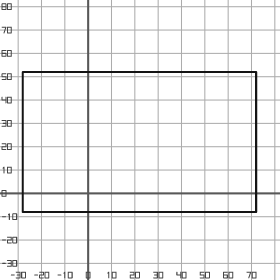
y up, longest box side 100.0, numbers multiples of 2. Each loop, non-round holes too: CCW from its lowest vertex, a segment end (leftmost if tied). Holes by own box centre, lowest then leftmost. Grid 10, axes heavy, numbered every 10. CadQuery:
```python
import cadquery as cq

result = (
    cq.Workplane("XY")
    .moveTo(-28.0, -8.0)
    .lineTo(72.0, -8.0)
    .lineTo(72.0, 52.0)
    .lineTo(-28.0, 52.0)
    .close()
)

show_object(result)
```